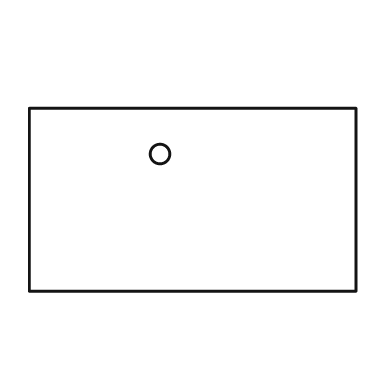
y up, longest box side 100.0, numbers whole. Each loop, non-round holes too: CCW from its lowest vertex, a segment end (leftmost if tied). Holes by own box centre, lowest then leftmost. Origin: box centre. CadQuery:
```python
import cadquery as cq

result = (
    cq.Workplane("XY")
    .moveTo(-50.0, -28.0)
    .lineTo(50.0, -28.0)
    .lineTo(50.0, 28.0)
    .lineTo(-50.0, 28.0)
    .close()
    .moveTo(-10.0, 14.0)
    .circle(3.0)
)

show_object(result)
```